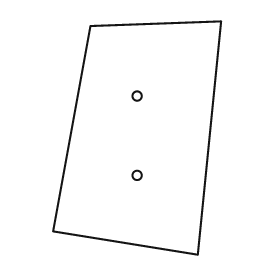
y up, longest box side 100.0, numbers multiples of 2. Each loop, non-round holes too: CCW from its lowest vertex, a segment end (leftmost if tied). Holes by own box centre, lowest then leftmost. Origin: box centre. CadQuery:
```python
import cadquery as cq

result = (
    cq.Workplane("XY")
    .moveTo(26.0, -50.0)
    .lineTo(36.0, 50.0)
    .lineTo(-20.0, 48.0)
    .lineTo(-36.0, -40.0)
    .close()
    .moveTo(0.0, -16.0)
    .circle(2.0)
    .moveTo(0.0, 18.0)
    .circle(2.0)
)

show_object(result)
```